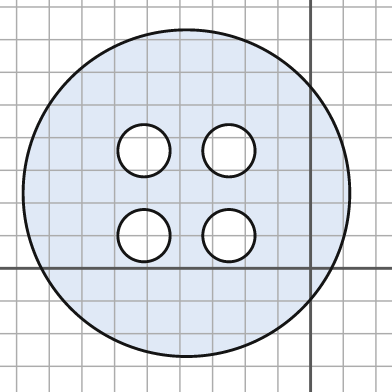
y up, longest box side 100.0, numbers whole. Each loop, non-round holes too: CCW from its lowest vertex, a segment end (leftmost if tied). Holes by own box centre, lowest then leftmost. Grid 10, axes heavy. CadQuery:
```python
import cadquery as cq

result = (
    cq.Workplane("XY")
    .moveTo(-38.0, 23.0)
    .circle(50.0)
    .moveTo(-51.0, 10.0)
    .circle(8.0)
    .moveTo(-25.0, 10.0)
    .circle(8.0)
    .moveTo(-51.0, 36.0)
    .circle(8.0)
    .moveTo(-25.0, 36.0)
    .circle(8.0)
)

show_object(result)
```